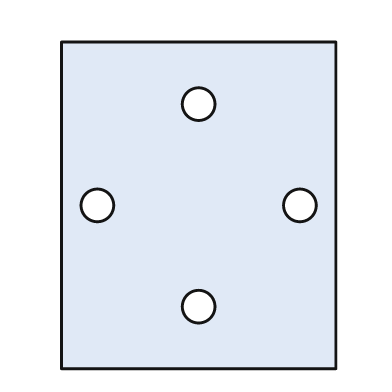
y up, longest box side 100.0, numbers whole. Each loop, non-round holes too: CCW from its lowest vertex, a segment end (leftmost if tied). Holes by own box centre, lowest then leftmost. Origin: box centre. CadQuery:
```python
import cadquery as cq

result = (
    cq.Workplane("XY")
    .moveTo(-42.0, -50.0)
    .lineTo(42.0, -50.0)
    .lineTo(42.0, 50.0)
    .lineTo(-42.0, 50.0)
    .close()
    .moveTo(0.0, -31.0)
    .circle(5.0)
    .moveTo(-31.0, 0.0)
    .circle(5.0)
    .moveTo(31.0, 0.0)
    .circle(5.0)
    .moveTo(0.0, 31.0)
    .circle(5.0)
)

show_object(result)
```